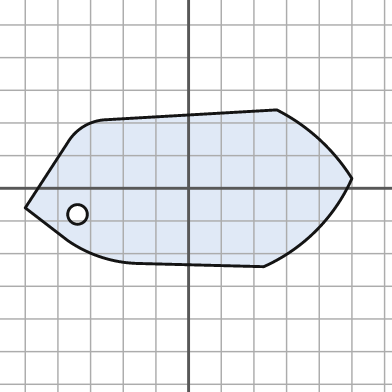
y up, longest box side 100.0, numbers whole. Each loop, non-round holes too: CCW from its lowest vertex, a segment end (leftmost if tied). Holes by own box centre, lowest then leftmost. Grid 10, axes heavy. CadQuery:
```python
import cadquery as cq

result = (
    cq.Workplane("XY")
    .moveTo(23.0, -24.0)
    .threePointArc((39.0, -13.0), (50.0, 3.0))
    .threePointArc((40.0, 15.0), (27.0, 24.0))
    .lineTo(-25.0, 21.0)
    .threePointArc((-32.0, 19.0), (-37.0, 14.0))
    .lineTo(-50.0, -6.0)
    .lineTo(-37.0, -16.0)
    .threePointArc((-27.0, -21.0), (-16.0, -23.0))
    .close()
    .moveTo(-34.0, -8.0)
    .circle(3.0)
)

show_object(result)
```